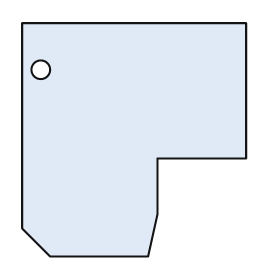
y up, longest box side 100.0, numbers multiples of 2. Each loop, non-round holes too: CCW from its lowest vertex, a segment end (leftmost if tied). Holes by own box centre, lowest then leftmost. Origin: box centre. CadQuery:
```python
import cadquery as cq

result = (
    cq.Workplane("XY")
    .moveTo(-36.0, -50.0)
    .lineTo(6.0, -50.0)
    .lineTo(10.0, -32.0)
    .lineTo(10.0, -8.0)
    .lineTo(48.0, -8.0)
    .lineTo(48.0, 50.0)
    .lineTo(-48.0, 50.0)
    .lineTo(-48.0, -38.0)
    .close()
    .moveTo(-40.0, 30.0)
    .circle(4.0)
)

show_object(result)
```